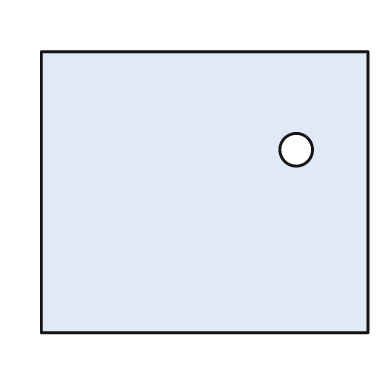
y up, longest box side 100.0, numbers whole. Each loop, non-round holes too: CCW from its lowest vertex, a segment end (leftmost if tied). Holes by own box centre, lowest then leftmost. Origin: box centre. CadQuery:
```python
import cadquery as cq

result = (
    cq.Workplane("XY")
    .moveTo(-50.0, -43.0)
    .lineTo(50.0, -43.0)
    .lineTo(50.0, 43.0)
    .lineTo(-50.0, 43.0)
    .close()
    .moveTo(28.0, 13.0)
    .circle(5.0)
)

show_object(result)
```